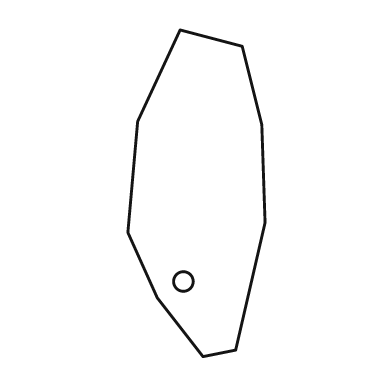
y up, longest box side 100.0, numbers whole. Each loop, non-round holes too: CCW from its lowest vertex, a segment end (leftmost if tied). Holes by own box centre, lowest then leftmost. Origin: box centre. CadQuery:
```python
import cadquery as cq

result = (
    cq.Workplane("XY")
    .moveTo(2.0, -50.0)
    .lineTo(12.0, -48.0)
    .lineTo(21.0, -9.0)
    .lineTo(20.0, 21.0)
    .lineTo(14.0, 45.0)
    .lineTo(-5.0, 50.0)
    .lineTo(-18.0, 22.0)
    .lineTo(-21.0, -12.0)
    .lineTo(-12.0, -32.0)
    .close()
    .moveTo(-4.0, -27.0)
    .circle(3.0)
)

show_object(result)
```